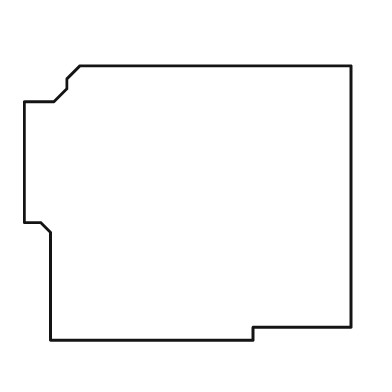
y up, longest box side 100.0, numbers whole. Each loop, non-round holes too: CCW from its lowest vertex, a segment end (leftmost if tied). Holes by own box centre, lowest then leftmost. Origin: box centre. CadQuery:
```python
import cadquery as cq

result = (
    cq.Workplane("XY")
    .moveTo(-42.0, -42.0)
    .lineTo(20.0, -42.0)
    .lineTo(20.0, -38.0)
    .lineTo(50.0, -38.0)
    .lineTo(50.0, 42.0)
    .lineTo(-33.0, 42.0)
    .lineTo(-37.0, 38.0)
    .lineTo(-37.0, 35.0)
    .lineTo(-41.0, 31.0)
    .lineTo(-50.0, 31.0)
    .lineTo(-50.0, -6.0)
    .lineTo(-45.0, -6.0)
    .lineTo(-42.0, -9.0)
    .close()
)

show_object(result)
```